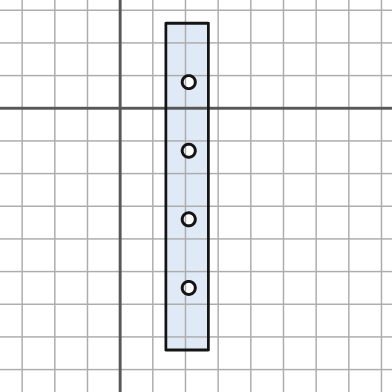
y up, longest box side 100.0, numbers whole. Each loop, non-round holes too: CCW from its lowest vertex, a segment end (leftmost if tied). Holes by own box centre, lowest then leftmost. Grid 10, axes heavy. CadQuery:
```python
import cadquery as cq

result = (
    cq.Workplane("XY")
    .moveTo(14.0, -74.0)
    .lineTo(27.0, -74.0)
    .lineTo(27.0, 26.0)
    .lineTo(14.0, 26.0)
    .close()
    .moveTo(21.0, -55.0)
    .circle(2.0)
    .moveTo(21.0, -34.0)
    .circle(2.0)
    .moveTo(21.0, -13.0)
    .circle(2.0)
    .moveTo(21.0, 8.0)
    .circle(2.0)
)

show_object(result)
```